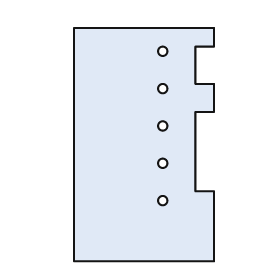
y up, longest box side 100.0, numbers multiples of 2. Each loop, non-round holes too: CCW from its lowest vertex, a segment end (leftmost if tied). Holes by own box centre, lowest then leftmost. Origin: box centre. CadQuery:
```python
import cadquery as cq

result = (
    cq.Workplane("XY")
    .moveTo(-30.0, -50.0)
    .lineTo(30.0, -50.0)
    .lineTo(30.0, -20.0)
    .lineTo(22.0, -20.0)
    .lineTo(22.0, 14.0)
    .lineTo(30.0, 14.0)
    .lineTo(30.0, 26.0)
    .lineTo(22.0, 26.0)
    .lineTo(22.0, 42.0)
    .lineTo(30.0, 42.0)
    .lineTo(30.0, 50.0)
    .lineTo(-30.0, 50.0)
    .close()
    .moveTo(8.0, -24.0)
    .circle(2.0)
    .moveTo(8.0, -8.0)
    .circle(2.0)
    .moveTo(8.0, 8.0)
    .circle(2.0)
    .moveTo(8.0, 24.0)
    .circle(2.0)
    .moveTo(8.0, 40.0)
    .circle(2.0)
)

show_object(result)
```